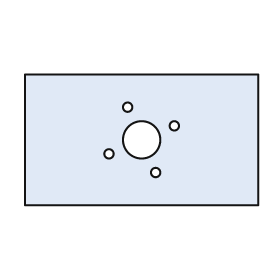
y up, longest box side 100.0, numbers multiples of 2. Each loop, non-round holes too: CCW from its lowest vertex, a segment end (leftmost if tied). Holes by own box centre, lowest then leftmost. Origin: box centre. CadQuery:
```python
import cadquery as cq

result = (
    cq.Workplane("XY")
    .moveTo(-50.0, -28.0)
    .lineTo(50.0, -28.0)
    .lineTo(50.0, 28.0)
    .lineTo(-50.0, 28.0)
    .close()
    .moveTo(6.0, -14.0)
    .circle(2.0)
    .moveTo(-14.0, -6.0)
    .circle(2.0)
    .moveTo(0.0, 0.0)
    .circle(8.0)
    .moveTo(14.0, 6.0)
    .circle(2.0)
    .moveTo(-6.0, 14.0)
    .circle(2.0)
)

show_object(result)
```